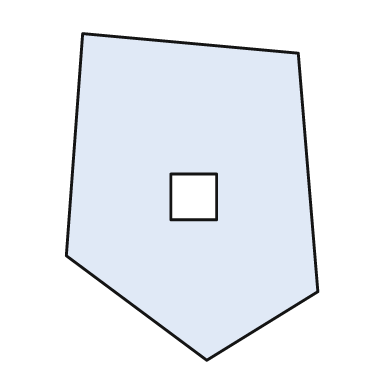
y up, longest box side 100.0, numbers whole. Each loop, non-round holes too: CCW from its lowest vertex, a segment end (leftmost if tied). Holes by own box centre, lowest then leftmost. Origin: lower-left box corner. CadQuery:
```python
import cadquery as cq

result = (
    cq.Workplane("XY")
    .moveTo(43.0, 0.0)
    .lineTo(77.0, 21.0)
    .lineTo(71.0, 94.0)
    .lineTo(5.0, 100.0)
    .lineTo(0.0, 32.0)
    .close()
    .moveTo(32.0, 43.0)
    .lineTo(46.0, 43.0)
    .lineTo(46.0, 57.0)
    .lineTo(32.0, 57.0)
    .close()
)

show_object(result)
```